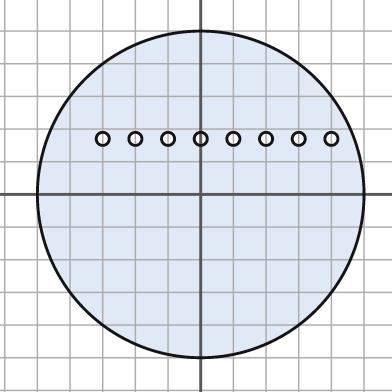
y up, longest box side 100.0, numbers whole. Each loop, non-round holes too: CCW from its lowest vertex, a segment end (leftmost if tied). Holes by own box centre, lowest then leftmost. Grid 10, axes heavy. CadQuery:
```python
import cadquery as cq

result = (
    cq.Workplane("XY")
    .moveTo(0.0, 0.0)
    .circle(50.0)
    .moveTo(-30.0, 17.0)
    .circle(2.0)
    .moveTo(-20.0, 17.0)
    .circle(2.0)
    .moveTo(-10.0, 17.0)
    .circle(2.0)
    .moveTo(0.0, 17.0)
    .circle(2.0)
    .moveTo(10.0, 17.0)
    .circle(2.0)
    .moveTo(20.0, 17.0)
    .circle(2.0)
    .moveTo(30.0, 17.0)
    .circle(2.0)
    .moveTo(40.0, 17.0)
    .circle(2.0)
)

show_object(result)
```